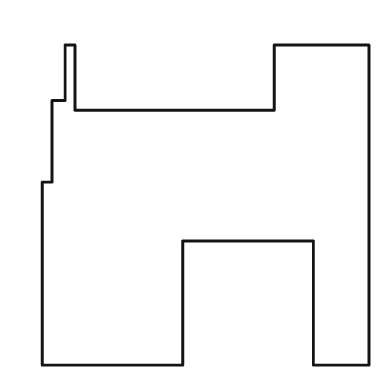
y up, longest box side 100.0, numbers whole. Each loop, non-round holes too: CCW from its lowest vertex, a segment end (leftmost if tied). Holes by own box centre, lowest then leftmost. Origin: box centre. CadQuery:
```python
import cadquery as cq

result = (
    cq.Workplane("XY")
    .moveTo(-50.0, -49.0)
    .lineTo(-7.0, -49.0)
    .lineTo(-7.0, -11.0)
    .lineTo(33.0, -11.0)
    .lineTo(33.0, -49.0)
    .lineTo(50.0, -49.0)
    .lineTo(50.0, 49.0)
    .lineTo(21.0, 49.0)
    .lineTo(21.0, 29.0)
    .lineTo(-40.0, 29.0)
    .lineTo(-40.0, 49.0)
    .lineTo(-43.0, 49.0)
    .lineTo(-43.0, 32.0)
    .lineTo(-47.0, 32.0)
    .lineTo(-47.0, 7.0)
    .lineTo(-50.0, 7.0)
    .close()
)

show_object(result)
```